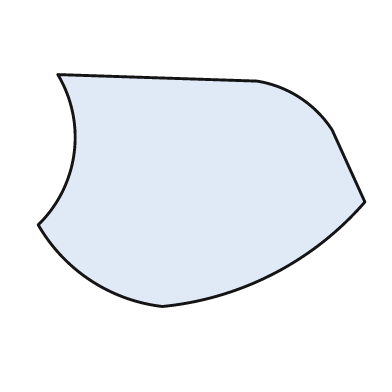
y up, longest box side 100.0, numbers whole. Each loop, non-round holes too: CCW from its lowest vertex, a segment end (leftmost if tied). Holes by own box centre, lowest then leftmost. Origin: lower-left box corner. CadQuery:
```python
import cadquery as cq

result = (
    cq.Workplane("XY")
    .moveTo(38.0, 0.0)
    .threePointArc((72.0, 10.0), (100.0, 32.0))
    .lineTo(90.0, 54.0)
    .threePointArc((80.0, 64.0), (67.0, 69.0))
    .lineTo(6.0, 71.0)
    .threePointArc((11.0, 47.0), (0.0, 25.0))
    .threePointArc((16.0, 8.0), (38.0, 0.0))
    .close()
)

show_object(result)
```